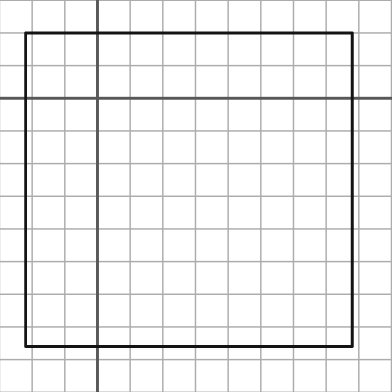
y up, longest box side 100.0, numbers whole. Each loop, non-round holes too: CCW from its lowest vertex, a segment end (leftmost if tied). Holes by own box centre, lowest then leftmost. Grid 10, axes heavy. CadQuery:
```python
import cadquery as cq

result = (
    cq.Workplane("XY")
    .moveTo(-22.0, -76.0)
    .lineTo(78.0, -76.0)
    .lineTo(78.0, 20.0)
    .lineTo(-22.0, 20.0)
    .close()
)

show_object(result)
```